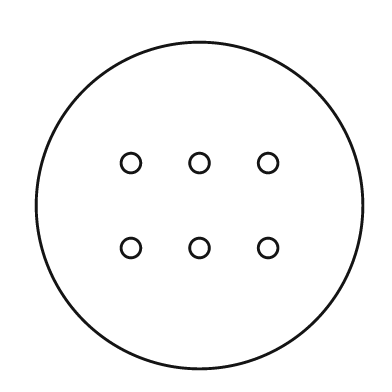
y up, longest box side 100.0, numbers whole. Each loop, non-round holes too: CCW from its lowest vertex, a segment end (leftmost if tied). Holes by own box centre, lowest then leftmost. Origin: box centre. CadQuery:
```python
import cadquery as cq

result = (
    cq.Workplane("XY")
    .moveTo(0.0, 0.0)
    .circle(50.0)
    .moveTo(-21.0, -13.0)
    .circle(3.0)
    .moveTo(0.0, -13.0)
    .circle(3.0)
    .moveTo(21.0, -13.0)
    .circle(3.0)
    .moveTo(-21.0, 13.0)
    .circle(3.0)
    .moveTo(0.0, 13.0)
    .circle(3.0)
    .moveTo(21.0, 13.0)
    .circle(3.0)
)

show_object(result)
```